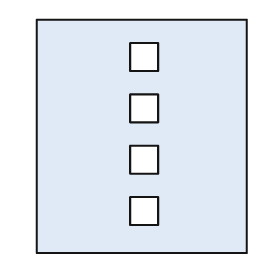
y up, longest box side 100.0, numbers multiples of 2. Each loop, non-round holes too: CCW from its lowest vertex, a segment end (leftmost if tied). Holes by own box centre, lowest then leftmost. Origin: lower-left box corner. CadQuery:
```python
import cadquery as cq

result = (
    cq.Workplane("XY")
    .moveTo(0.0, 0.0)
    .lineTo(90.0, 0.0)
    .lineTo(90.0, 100.0)
    .lineTo(0.0, 100.0)
    .close()
    .moveTo(40.0, 12.0)
    .lineTo(52.0, 12.0)
    .lineTo(52.0, 24.0)
    .lineTo(40.0, 24.0)
    .close()
    .moveTo(40.0, 34.0)
    .lineTo(52.0, 34.0)
    .lineTo(52.0, 46.0)
    .lineTo(40.0, 46.0)
    .close()
    .moveTo(40.0, 56.0)
    .lineTo(52.0, 56.0)
    .lineTo(52.0, 68.0)
    .lineTo(40.0, 68.0)
    .close()
    .moveTo(40.0, 78.0)
    .lineTo(52.0, 78.0)
    .lineTo(52.0, 90.0)
    .lineTo(40.0, 90.0)
    .close()
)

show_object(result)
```